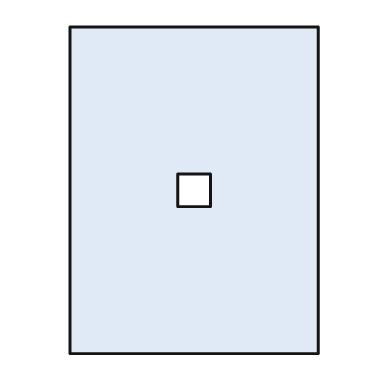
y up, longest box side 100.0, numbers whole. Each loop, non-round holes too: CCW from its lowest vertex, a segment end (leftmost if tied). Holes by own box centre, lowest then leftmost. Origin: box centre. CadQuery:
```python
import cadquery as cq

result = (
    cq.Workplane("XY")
    .moveTo(-38.0, -50.0)
    .lineTo(38.0, -50.0)
    .lineTo(38.0, 50.0)
    .lineTo(-38.0, 50.0)
    .close()
    .moveTo(-5.0, -5.0)
    .lineTo(5.0, -5.0)
    .lineTo(5.0, 5.0)
    .lineTo(-5.0, 5.0)
    .close()
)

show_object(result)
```